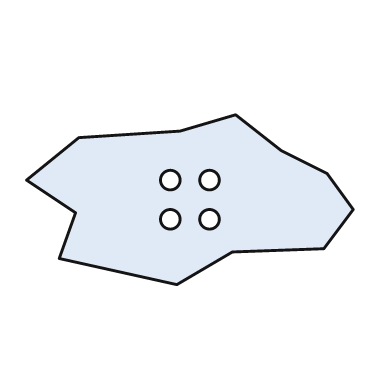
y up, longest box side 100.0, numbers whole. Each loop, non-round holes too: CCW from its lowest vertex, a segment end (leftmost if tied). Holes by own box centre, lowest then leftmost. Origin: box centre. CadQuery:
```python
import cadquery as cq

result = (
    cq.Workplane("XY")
    .moveTo(-4.0, -26.0)
    .lineTo(13.0, -16.0)
    .lineTo(41.0, -15.0)
    .lineTo(50.0, -3.0)
    .lineTo(42.0, 8.0)
    .lineTo(28.0, 15.0)
    .lineTo(14.0, 26.0)
    .lineTo(-3.0, 21.0)
    .lineTo(-34.0, 19.0)
    .lineTo(-50.0, 6.0)
    .lineTo(-35.0, -4.0)
    .lineTo(-40.0, -18.0)
    .close()
    .moveTo(-6.0, -6.0)
    .circle(3.0)
    .moveTo(6.0, -6.0)
    .circle(3.0)
    .moveTo(-6.0, 6.0)
    .circle(3.0)
    .moveTo(6.0, 6.0)
    .circle(3.0)
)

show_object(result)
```